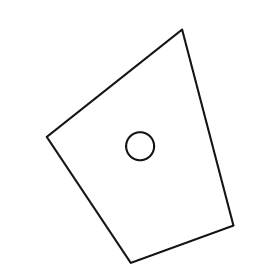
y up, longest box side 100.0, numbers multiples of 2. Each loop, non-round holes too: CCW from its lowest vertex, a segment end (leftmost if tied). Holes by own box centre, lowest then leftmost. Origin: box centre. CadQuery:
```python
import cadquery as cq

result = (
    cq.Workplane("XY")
    .moveTo(-4.0, -50.0)
    .lineTo(40.0, -34.0)
    .lineTo(18.0, 50.0)
    .lineTo(-40.0, 4.0)
    .close()
    .moveTo(0.0, 0.0)
    .circle(6.0)
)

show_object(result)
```